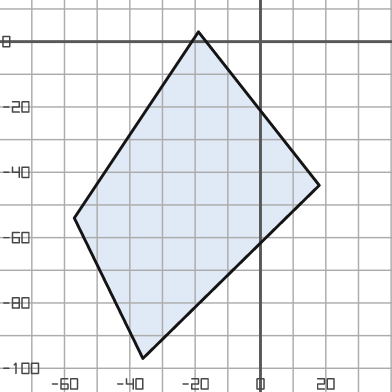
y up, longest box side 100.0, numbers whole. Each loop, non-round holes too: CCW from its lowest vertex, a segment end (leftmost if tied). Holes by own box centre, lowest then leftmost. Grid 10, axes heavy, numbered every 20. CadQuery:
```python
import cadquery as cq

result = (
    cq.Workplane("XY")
    .moveTo(-36.0, -97.0)
    .lineTo(18.0, -44.0)
    .lineTo(-19.0, 3.0)
    .lineTo(-57.0, -54.0)
    .close()
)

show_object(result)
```